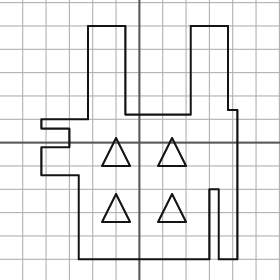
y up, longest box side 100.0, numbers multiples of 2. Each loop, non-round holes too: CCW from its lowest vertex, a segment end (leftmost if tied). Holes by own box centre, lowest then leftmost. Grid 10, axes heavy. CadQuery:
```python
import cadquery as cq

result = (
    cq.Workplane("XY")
    .moveTo(-26.0, -50.0)
    .lineTo(30.0, -50.0)
    .lineTo(30.0, -20.0)
    .lineTo(34.0, -20.0)
    .lineTo(34.0, -50.0)
    .lineTo(42.0, -50.0)
    .lineTo(42.0, 14.0)
    .lineTo(38.0, 14.0)
    .lineTo(38.0, 50.0)
    .lineTo(22.0, 50.0)
    .lineTo(22.0, 12.0)
    .lineTo(-6.0, 12.0)
    .lineTo(-6.0, 50.0)
    .lineTo(-22.0, 50.0)
    .lineTo(-22.0, 10.0)
    .lineTo(-42.0, 10.0)
    .lineTo(-42.0, 6.0)
    .lineTo(-30.0, 6.0)
    .lineTo(-30.0, -2.0)
    .lineTo(-42.0, -2.0)
    .lineTo(-42.0, -14.0)
    .lineTo(-26.0, -14.0)
    .close()
    .moveTo(-16.0, -34.0)
    .lineTo(-4.0, -34.0)
    .lineTo(-10.0, -22.0)
    .close()
    .moveTo(8.0, -34.0)
    .lineTo(20.0, -34.0)
    .lineTo(14.0, -22.0)
    .close()
    .moveTo(-16.0, -10.0)
    .lineTo(-4.0, -10.0)
    .lineTo(-10.0, 2.0)
    .close()
    .moveTo(8.0, -10.0)
    .lineTo(20.0, -10.0)
    .lineTo(14.0, 2.0)
    .close()
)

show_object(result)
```